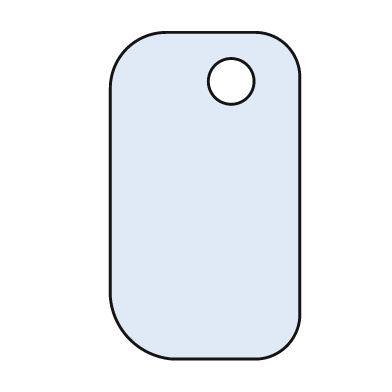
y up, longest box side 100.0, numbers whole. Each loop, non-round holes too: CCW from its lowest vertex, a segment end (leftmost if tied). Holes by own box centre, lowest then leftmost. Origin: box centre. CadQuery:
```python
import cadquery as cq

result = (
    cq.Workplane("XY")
    .moveTo(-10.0, -50.0)
    .lineTo(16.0, -50.0)
    .threePointArc((25.0, -46.0), (29.0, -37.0))
    .lineTo(29.0, 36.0)
    .threePointArc((25.0, 46.0), (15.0, 50.0))
    .lineTo(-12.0, 50.0)
    .threePointArc((-24.0, 45.0), (-29.0, 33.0))
    .lineTo(-29.0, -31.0)
    .threePointArc((-23.0, -44.0), (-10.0, -50.0))
    .close()
    .moveTo(8.0, 35.0)
    .circle(7.0)
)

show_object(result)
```